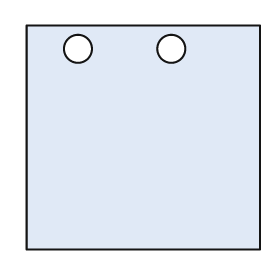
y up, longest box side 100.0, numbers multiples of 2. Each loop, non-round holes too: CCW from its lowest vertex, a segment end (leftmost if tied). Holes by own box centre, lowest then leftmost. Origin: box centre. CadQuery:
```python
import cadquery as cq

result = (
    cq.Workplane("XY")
    .moveTo(-50.0, -48.0)
    .lineTo(50.0, -48.0)
    .lineTo(50.0, 48.0)
    .lineTo(-50.0, 48.0)
    .close()
    .moveTo(-28.0, 38.0)
    .circle(6.0)
    .moveTo(12.0, 38.0)
    .circle(6.0)
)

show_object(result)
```